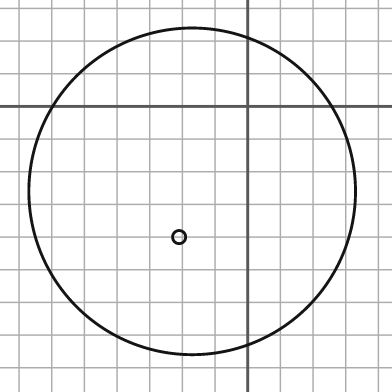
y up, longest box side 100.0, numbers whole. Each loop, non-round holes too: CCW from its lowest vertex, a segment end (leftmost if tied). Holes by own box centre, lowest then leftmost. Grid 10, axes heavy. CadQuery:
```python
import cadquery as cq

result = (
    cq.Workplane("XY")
    .moveTo(-17.0, -26.0)
    .circle(50.0)
    .moveTo(-21.0, -40.0)
    .circle(2.0)
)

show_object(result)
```